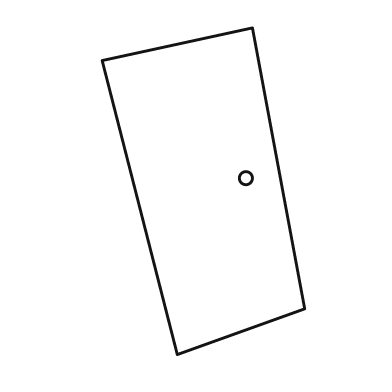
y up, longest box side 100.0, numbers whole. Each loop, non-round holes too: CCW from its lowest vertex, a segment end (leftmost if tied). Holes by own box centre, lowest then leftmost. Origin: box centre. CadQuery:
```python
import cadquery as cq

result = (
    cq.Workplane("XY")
    .moveTo(-8.0, -50.0)
    .lineTo(31.0, -36.0)
    .lineTo(15.0, 50.0)
    .lineTo(-31.0, 40.0)
    .close()
    .moveTo(13.0, 4.0)
    .circle(2.0)
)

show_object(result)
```